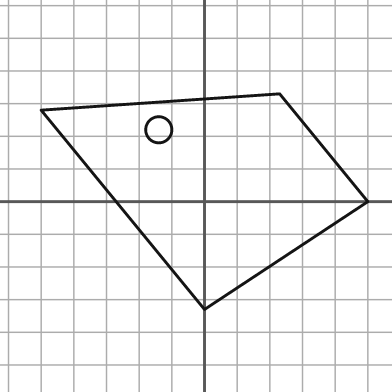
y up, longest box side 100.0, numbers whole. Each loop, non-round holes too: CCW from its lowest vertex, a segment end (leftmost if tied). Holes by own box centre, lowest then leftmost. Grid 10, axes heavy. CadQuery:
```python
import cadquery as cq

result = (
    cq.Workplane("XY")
    .moveTo(0.0, -33.0)
    .lineTo(50.0, 0.0)
    .lineTo(23.0, 33.0)
    .lineTo(-50.0, 28.0)
    .close()
    .moveTo(-14.0, 22.0)
    .circle(4.0)
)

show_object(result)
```